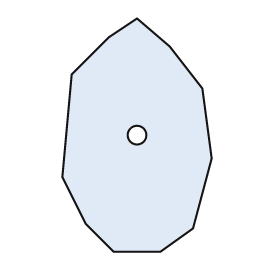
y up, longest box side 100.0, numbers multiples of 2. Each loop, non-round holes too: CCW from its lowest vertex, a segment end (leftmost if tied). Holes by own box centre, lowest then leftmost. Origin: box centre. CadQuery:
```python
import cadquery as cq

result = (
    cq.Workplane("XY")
    .moveTo(-10.0, -50.0)
    .lineTo(10.0, -50.0)
    .lineTo(24.0, -40.0)
    .lineTo(32.0, -10.0)
    .lineTo(28.0, 20.0)
    .lineTo(14.0, 38.0)
    .lineTo(0.0, 50.0)
    .lineTo(-12.0, 42.0)
    .lineTo(-28.0, 26.0)
    .lineTo(-32.0, -18.0)
    .lineTo(-22.0, -38.0)
    .close()
    .moveTo(0.0, 0.0)
    .circle(4.0)
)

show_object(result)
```